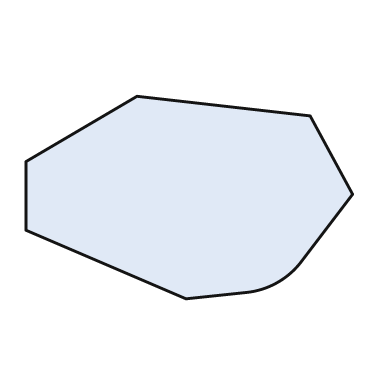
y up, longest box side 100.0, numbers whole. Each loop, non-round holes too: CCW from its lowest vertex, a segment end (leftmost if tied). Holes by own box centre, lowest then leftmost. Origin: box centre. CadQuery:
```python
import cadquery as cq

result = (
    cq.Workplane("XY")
    .moveTo(-1.0, -31.0)
    .lineTo(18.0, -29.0)
    .threePointArc((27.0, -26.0), (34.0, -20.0))
    .lineTo(50.0, 1.0)
    .lineTo(37.0, 25.0)
    .lineTo(-16.0, 31.0)
    .lineTo(-50.0, 11.0)
    .lineTo(-50.0, -10.0)
    .close()
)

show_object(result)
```